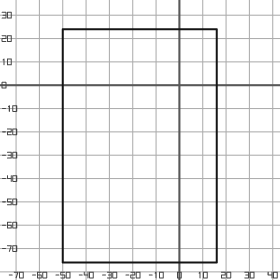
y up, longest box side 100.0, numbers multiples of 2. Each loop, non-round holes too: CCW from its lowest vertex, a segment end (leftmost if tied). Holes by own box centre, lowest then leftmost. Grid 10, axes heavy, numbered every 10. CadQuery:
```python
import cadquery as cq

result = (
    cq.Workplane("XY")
    .moveTo(-50.0, -76.0)
    .lineTo(16.0, -76.0)
    .lineTo(16.0, 24.0)
    .lineTo(-50.0, 24.0)
    .close()
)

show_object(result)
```